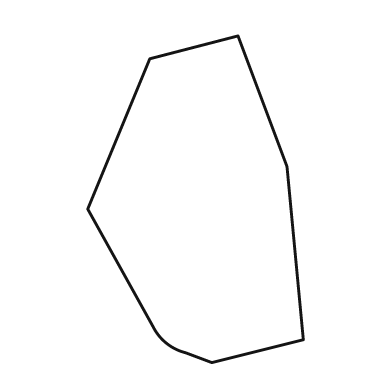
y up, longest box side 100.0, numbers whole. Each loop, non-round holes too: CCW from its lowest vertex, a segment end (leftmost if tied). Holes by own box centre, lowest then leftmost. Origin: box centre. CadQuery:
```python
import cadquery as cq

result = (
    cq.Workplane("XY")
    .moveTo(5.0, -50.0)
    .lineTo(33.0, -43.0)
    .lineTo(28.0, 10.0)
    .lineTo(13.0, 50.0)
    .lineTo(-14.0, 43.0)
    .lineTo(-33.0, -3.0)
    .lineTo(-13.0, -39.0)
    .threePointArc((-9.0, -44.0), (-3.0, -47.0))
    .close()
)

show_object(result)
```